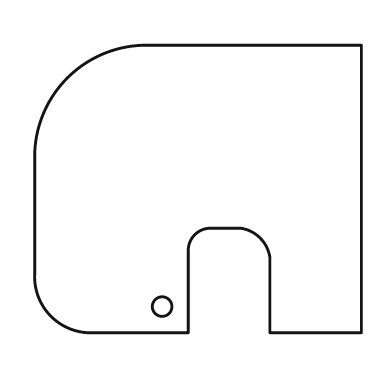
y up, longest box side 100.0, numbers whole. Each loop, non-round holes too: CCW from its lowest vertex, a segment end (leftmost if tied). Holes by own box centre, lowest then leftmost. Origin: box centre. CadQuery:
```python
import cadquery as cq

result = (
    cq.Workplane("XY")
    .moveTo(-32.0, -44.0)
    .lineTo(-3.0, -44.0)
    .lineTo(-3.0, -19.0)
    .threePointArc((-1.0, -14.0), (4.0, -12.0))
    .lineTo(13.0, -12.0)
    .threePointArc((19.0, -15.0), (22.0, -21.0))
    .lineTo(22.0, -44.0)
    .lineTo(50.0, -44.0)
    .lineTo(50.0, 44.0)
    .lineTo(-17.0, 44.0)
    .threePointArc((-40.0, 34.0), (-50.0, 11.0))
    .lineTo(-50.0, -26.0)
    .threePointArc((-45.0, -39.0), (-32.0, -44.0))
    .close()
    .moveTo(-11.0, -36.0)
    .circle(3.0)
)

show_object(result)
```